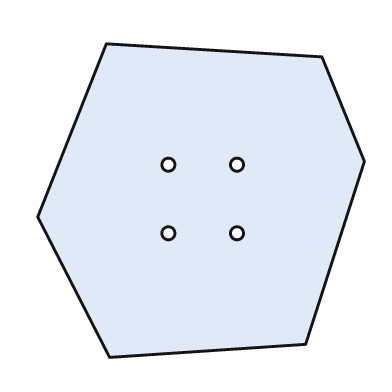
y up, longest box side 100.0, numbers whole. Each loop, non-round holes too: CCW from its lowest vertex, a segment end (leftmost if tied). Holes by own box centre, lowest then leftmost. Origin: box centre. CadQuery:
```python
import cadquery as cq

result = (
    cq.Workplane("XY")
    .moveTo(-28.0, -48.0)
    .lineTo(32.0, -44.0)
    .lineTo(50.0, 12.0)
    .lineTo(37.0, 44.0)
    .lineTo(-29.0, 48.0)
    .lineTo(-50.0, -5.0)
    .close()
    .moveTo(-10.0, -10.0)
    .circle(2.0)
    .moveTo(11.0, -10.0)
    .circle(2.0)
    .moveTo(-10.0, 11.0)
    .circle(2.0)
    .moveTo(11.0, 11.0)
    .circle(2.0)
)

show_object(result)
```